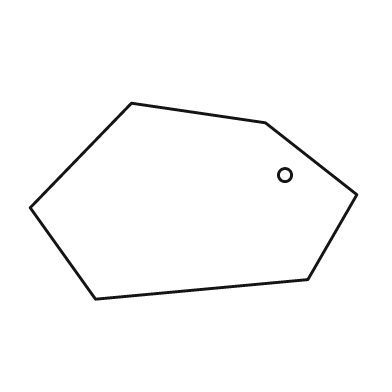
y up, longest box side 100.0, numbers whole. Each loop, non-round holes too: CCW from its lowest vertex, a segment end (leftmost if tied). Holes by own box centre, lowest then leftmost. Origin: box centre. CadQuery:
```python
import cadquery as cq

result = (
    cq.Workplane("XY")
    .moveTo(-30.0, -30.0)
    .lineTo(35.0, -24.0)
    .lineTo(50.0, 2.0)
    .lineTo(22.0, 24.0)
    .lineTo(-19.0, 30.0)
    .lineTo(-50.0, -2.0)
    .close()
    .moveTo(28.0, 8.0)
    .circle(2.0)
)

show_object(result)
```